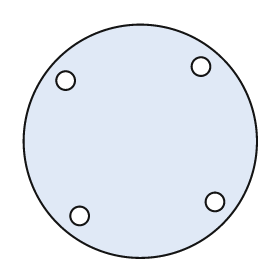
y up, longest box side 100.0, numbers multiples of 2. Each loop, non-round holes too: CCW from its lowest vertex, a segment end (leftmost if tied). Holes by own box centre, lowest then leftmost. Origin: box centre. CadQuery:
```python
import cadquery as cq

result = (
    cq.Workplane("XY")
    .moveTo(0.0, 0.0)
    .circle(50.0)
    .moveTo(-26.0, -32.0)
    .circle(4.0)
    .moveTo(32.0, -26.0)
    .circle(4.0)
    .moveTo(-32.0, 26.0)
    .circle(4.0)
    .moveTo(26.0, 32.0)
    .circle(4.0)
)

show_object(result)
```